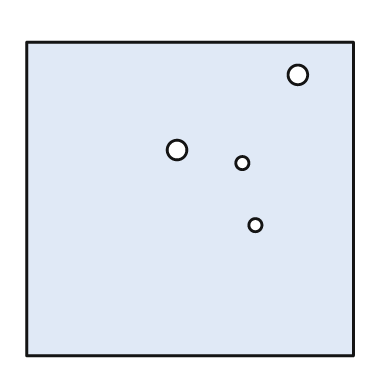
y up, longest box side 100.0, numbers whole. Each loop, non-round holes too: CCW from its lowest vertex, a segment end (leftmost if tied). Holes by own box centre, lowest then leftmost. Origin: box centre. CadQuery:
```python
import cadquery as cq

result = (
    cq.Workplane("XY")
    .moveTo(-50.0, -48.0)
    .lineTo(50.0, -48.0)
    .lineTo(50.0, 48.0)
    .lineTo(-50.0, 48.0)
    .close()
    .moveTo(20.0, -8.0)
    .circle(2.0)
    .moveTo(16.0, 11.0)
    .circle(2.0)
    .moveTo(-4.0, 15.0)
    .circle(3.0)
    .moveTo(33.0, 38.0)
    .circle(3.0)
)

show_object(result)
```